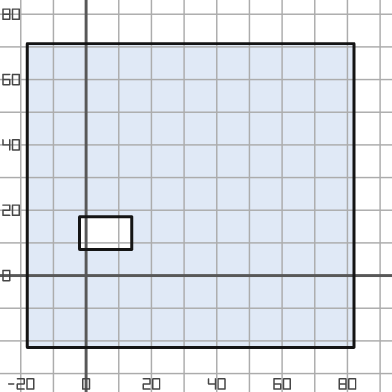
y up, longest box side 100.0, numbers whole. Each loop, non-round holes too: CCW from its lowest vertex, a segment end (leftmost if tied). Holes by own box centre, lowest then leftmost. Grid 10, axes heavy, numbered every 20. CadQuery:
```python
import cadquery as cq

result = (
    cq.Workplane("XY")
    .moveTo(-18.0, -22.0)
    .lineTo(82.0, -22.0)
    .lineTo(82.0, 71.0)
    .lineTo(-18.0, 71.0)
    .close()
    .moveTo(-2.0, 8.0)
    .lineTo(14.0, 8.0)
    .lineTo(14.0, 18.0)
    .lineTo(-2.0, 18.0)
    .close()
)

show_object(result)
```